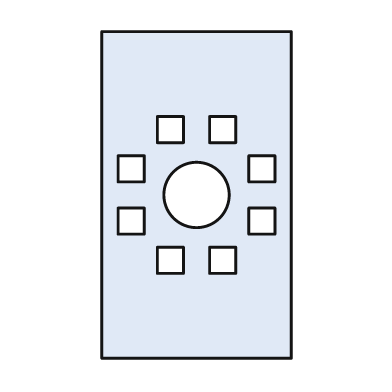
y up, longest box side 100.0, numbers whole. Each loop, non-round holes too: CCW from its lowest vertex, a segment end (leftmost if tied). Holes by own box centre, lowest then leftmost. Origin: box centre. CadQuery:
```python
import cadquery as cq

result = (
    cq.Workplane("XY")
    .moveTo(-29.0, -50.0)
    .lineTo(29.0, -50.0)
    .lineTo(29.0, 50.0)
    .lineTo(-29.0, 50.0)
    .close()
    .moveTo(-12.0, -24.0)
    .lineTo(-4.0, -24.0)
    .lineTo(-4.0, -16.0)
    .lineTo(-12.0, -16.0)
    .close()
    .moveTo(4.0, -24.0)
    .lineTo(12.0, -24.0)
    .lineTo(12.0, -16.0)
    .lineTo(4.0, -16.0)
    .close()
    .moveTo(-24.0, -12.0)
    .lineTo(-16.0, -12.0)
    .lineTo(-16.0, -4.0)
    .lineTo(-24.0, -4.0)
    .close()
    .moveTo(16.0, -12.0)
    .lineTo(24.0, -12.0)
    .lineTo(24.0, -4.0)
    .lineTo(16.0, -4.0)
    .close()
    .moveTo(0.0, 0.0)
    .circle(10.0)
    .moveTo(-24.0, 4.0)
    .lineTo(-16.0, 4.0)
    .lineTo(-16.0, 12.0)
    .lineTo(-24.0, 12.0)
    .close()
    .moveTo(16.0, 4.0)
    .lineTo(24.0, 4.0)
    .lineTo(24.0, 12.0)
    .lineTo(16.0, 12.0)
    .close()
    .moveTo(-12.0, 16.0)
    .lineTo(-4.0, 16.0)
    .lineTo(-4.0, 24.0)
    .lineTo(-12.0, 24.0)
    .close()
    .moveTo(4.0, 16.0)
    .lineTo(12.0, 16.0)
    .lineTo(12.0, 24.0)
    .lineTo(4.0, 24.0)
    .close()
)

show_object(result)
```